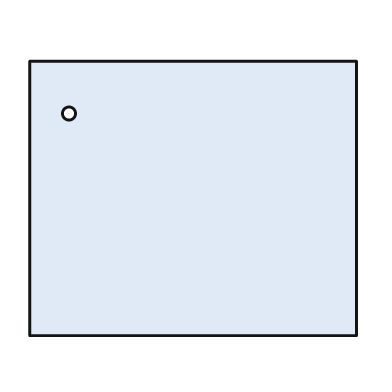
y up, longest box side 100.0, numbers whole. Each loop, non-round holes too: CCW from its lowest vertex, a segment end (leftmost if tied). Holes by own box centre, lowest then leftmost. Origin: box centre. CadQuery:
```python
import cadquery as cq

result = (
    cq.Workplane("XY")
    .moveTo(-50.0, -42.0)
    .lineTo(50.0, -42.0)
    .lineTo(50.0, 42.0)
    .lineTo(-50.0, 42.0)
    .close()
    .moveTo(-38.0, 26.0)
    .circle(2.0)
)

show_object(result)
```